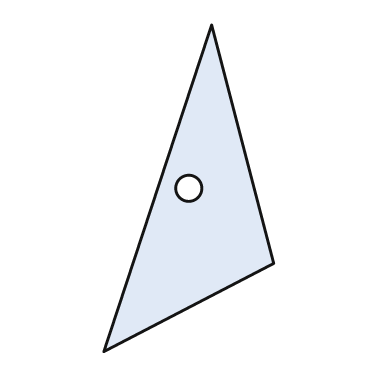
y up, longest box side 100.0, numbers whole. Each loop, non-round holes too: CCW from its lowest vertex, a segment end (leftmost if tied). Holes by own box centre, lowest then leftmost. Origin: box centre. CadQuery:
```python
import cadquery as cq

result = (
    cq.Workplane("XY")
    .moveTo(-26.0, -50.0)
    .lineTo(26.0, -23.0)
    .lineTo(7.0, 50.0)
    .close()
    .moveTo(0.0, 0.0)
    .circle(4.0)
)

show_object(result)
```